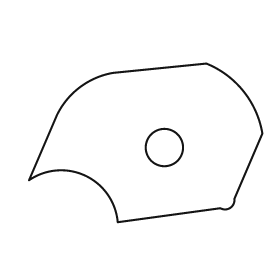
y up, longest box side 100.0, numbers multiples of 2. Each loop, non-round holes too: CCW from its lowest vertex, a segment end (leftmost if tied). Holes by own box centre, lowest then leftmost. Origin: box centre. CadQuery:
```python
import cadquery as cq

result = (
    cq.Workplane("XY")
    .moveTo(-12.0, -34.0)
    .lineTo(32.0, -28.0)
    .threePointArc((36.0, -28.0), (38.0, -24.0))
    .lineTo(50.0, 4.0)
    .threePointArc((42.0, 22.0), (26.0, 34.0))
    .lineTo(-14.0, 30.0)
    .threePointArc((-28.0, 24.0), (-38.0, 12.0))
    .lineTo(-50.0, -16.0)
    .threePointArc((-26.0, -14.0), (-12.0, -34.0))
    .close()
    .moveTo(8.0, -2.0)
    .circle(8.0)
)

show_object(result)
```